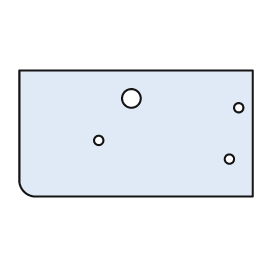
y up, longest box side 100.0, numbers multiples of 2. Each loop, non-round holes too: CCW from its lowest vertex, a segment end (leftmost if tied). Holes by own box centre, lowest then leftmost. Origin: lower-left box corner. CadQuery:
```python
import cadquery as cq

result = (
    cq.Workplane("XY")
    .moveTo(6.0, 0.0)
    .lineTo(100.0, 0.0)
    .lineTo(100.0, 54.0)
    .lineTo(0.0, 54.0)
    .lineTo(0.0, 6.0)
    .threePointArc((2.0, 2.0), (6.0, 0.0))
    .close()
    .moveTo(90.0, 16.0)
    .circle(2.0)
    .moveTo(34.0, 24.0)
    .circle(2.0)
    .moveTo(94.0, 38.0)
    .circle(2.0)
    .moveTo(48.0, 42.0)
    .circle(4.0)
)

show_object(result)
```